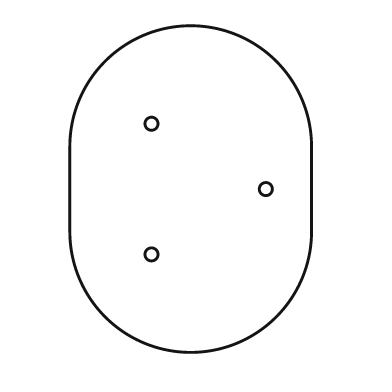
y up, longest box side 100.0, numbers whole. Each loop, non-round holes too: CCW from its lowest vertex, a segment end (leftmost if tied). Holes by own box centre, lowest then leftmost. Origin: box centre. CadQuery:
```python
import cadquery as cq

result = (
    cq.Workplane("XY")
    .moveTo(-37.0, -13.0)
    .threePointArc((0.0, -50.0), (37.0, -13.0))
    .lineTo(37.0, 13.0)
    .threePointArc((0.0, 50.0), (-37.0, 13.0))
    .close()
    .moveTo(-12.0, -20.0)
    .circle(2.0)
    .moveTo(23.0, 0.0)
    .circle(2.0)
    .moveTo(-12.0, 20.0)
    .circle(2.0)
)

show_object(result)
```